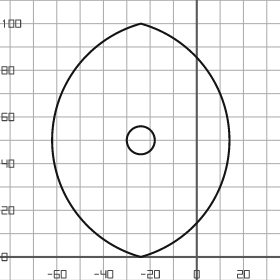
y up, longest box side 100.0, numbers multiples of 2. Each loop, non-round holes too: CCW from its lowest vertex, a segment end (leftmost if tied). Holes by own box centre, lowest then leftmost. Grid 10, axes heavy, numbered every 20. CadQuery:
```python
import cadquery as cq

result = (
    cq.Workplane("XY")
    .moveTo(-24.0, 0.0)
    .threePointArc((14.0, 50.0), (-24.0, 100.0))
    .threePointArc((-62.0, 50.0), (-24.0, 0.0))
    .close()
    .moveTo(-24.0, 50.0)
    .circle(6.0)
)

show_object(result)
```